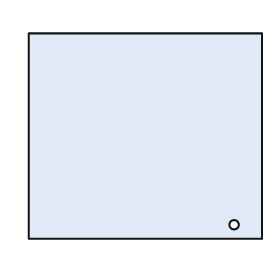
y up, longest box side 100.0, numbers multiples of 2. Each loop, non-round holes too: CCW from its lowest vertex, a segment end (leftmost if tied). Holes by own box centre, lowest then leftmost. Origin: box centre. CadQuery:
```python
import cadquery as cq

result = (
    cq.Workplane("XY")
    .moveTo(-50.0, -44.0)
    .lineTo(50.0, -44.0)
    .lineTo(50.0, 44.0)
    .lineTo(-50.0, 44.0)
    .close()
    .moveTo(38.0, -38.0)
    .circle(2.0)
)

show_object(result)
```